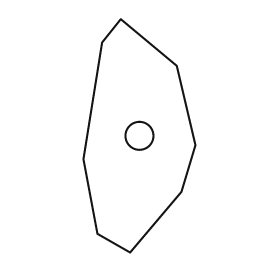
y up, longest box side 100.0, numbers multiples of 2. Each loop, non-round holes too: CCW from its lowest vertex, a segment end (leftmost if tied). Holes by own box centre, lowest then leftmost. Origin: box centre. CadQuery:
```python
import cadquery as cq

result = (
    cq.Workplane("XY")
    .moveTo(-4.0, -50.0)
    .lineTo(18.0, -24.0)
    .lineTo(24.0, -4.0)
    .lineTo(16.0, 30.0)
    .lineTo(-8.0, 50.0)
    .lineTo(-16.0, 40.0)
    .lineTo(-24.0, -10.0)
    .lineTo(-18.0, -42.0)
    .close()
    .moveTo(0.0, 0.0)
    .circle(6.0)
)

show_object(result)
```